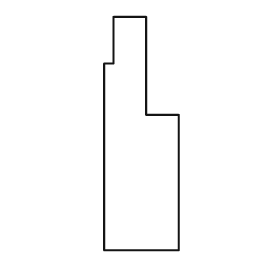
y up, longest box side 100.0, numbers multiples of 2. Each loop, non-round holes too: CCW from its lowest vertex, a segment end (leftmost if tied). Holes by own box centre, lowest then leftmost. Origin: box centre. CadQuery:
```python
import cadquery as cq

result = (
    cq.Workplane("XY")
    .moveTo(-16.0, -50.0)
    .lineTo(16.0, -50.0)
    .lineTo(16.0, 8.0)
    .lineTo(2.0, 8.0)
    .lineTo(2.0, 50.0)
    .lineTo(-12.0, 50.0)
    .lineTo(-12.0, 30.0)
    .lineTo(-16.0, 30.0)
    .close()
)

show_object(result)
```